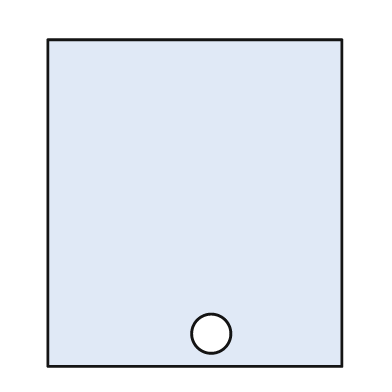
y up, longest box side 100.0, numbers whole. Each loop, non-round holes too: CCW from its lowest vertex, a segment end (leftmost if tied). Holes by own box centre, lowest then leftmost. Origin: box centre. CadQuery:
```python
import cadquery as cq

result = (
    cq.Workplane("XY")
    .moveTo(-45.0, -50.0)
    .lineTo(45.0, -50.0)
    .lineTo(45.0, 50.0)
    .lineTo(-45.0, 50.0)
    .close()
    .moveTo(5.0, -40.0)
    .circle(6.0)
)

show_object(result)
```